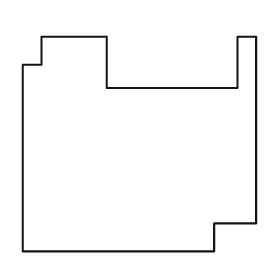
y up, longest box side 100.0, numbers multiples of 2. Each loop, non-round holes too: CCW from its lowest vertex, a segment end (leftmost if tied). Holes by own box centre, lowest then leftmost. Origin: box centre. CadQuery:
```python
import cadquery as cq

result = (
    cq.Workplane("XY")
    .moveTo(-50.0, -46.0)
    .lineTo(32.0, -46.0)
    .lineTo(32.0, -34.0)
    .lineTo(50.0, -34.0)
    .lineTo(50.0, 46.0)
    .lineTo(42.0, 46.0)
    .lineTo(42.0, 24.0)
    .lineTo(-14.0, 24.0)
    .lineTo(-14.0, 46.0)
    .lineTo(-42.0, 46.0)
    .lineTo(-42.0, 34.0)
    .lineTo(-50.0, 34.0)
    .close()
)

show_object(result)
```